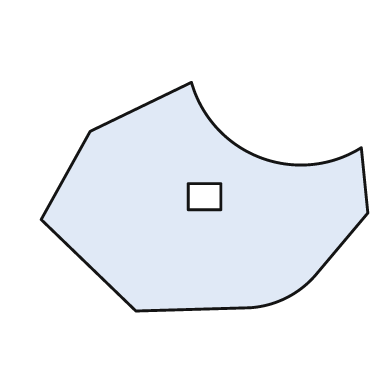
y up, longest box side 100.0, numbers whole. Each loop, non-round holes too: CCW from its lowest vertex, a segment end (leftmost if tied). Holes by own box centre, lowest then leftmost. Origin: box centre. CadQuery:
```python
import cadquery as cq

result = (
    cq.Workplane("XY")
    .moveTo(-21.0, -35.0)
    .lineTo(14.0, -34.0)
    .threePointArc((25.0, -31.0), (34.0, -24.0))
    .lineTo(50.0, -5.0)
    .lineTo(48.0, 15.0)
    .threePointArc((17.0, 12.0), (-4.0, 35.0))
    .lineTo(-35.0, 20.0)
    .lineTo(-50.0, -7.0)
    .close()
    .moveTo(-5.0, -4.0)
    .lineTo(5.0, -4.0)
    .lineTo(5.0, 4.0)
    .lineTo(-5.0, 4.0)
    .close()
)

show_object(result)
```